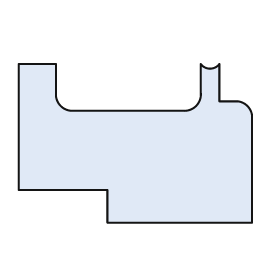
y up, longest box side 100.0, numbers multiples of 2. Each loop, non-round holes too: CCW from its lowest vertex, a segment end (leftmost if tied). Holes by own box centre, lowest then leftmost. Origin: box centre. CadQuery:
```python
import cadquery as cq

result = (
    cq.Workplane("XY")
    .moveTo(-12.0, -34.0)
    .lineTo(50.0, -34.0)
    .lineTo(50.0, 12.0)
    .threePointArc((48.0, 16.0), (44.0, 18.0))
    .lineTo(36.0, 18.0)
    .lineTo(36.0, 34.0)
    .threePointArc((32.0, 32.0), (28.0, 34.0))
    .lineTo(28.0, 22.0)
    .threePointArc((26.0, 16.0), (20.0, 14.0))
    .lineTo(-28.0, 14.0)
    .threePointArc((-32.0, 16.0), (-34.0, 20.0))
    .lineTo(-34.0, 34.0)
    .lineTo(-50.0, 34.0)
    .lineTo(-50.0, -20.0)
    .lineTo(-12.0, -20.0)
    .close()
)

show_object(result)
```